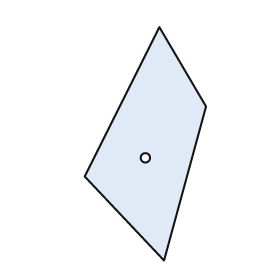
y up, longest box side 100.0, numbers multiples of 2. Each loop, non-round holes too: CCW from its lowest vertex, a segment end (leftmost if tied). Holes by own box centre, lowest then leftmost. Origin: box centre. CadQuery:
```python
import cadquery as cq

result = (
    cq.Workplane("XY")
    .moveTo(8.0, -50.0)
    .lineTo(26.0, 16.0)
    .lineTo(6.0, 50.0)
    .lineTo(-26.0, -14.0)
    .close()
    .moveTo(0.0, -6.0)
    .circle(2.0)
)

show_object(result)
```